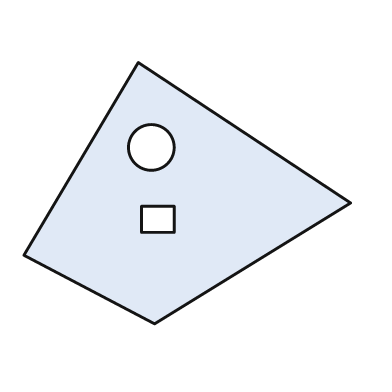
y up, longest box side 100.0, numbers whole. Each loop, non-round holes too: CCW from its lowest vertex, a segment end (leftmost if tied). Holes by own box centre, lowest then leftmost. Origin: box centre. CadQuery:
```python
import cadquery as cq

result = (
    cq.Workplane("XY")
    .moveTo(-10.0, -40.0)
    .lineTo(50.0, -3.0)
    .lineTo(-15.0, 40.0)
    .lineTo(-50.0, -19.0)
    .close()
    .moveTo(-14.0, -12.0)
    .lineTo(-4.0, -12.0)
    .lineTo(-4.0, -4.0)
    .lineTo(-14.0, -4.0)
    .close()
    .moveTo(-11.0, 14.0)
    .circle(7.0)
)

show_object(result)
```